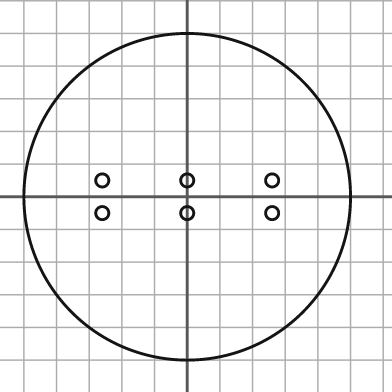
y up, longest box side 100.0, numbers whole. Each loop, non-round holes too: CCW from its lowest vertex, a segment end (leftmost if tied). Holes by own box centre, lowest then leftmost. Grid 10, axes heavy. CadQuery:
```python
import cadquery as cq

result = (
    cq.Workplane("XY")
    .moveTo(0.0, 0.0)
    .circle(50.0)
    .moveTo(-26.0, -5.0)
    .circle(2.0)
    .moveTo(0.0, -5.0)
    .circle(2.0)
    .moveTo(26.0, -5.0)
    .circle(2.0)
    .moveTo(-26.0, 5.0)
    .circle(2.0)
    .moveTo(0.0, 5.0)
    .circle(2.0)
    .moveTo(26.0, 5.0)
    .circle(2.0)
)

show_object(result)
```